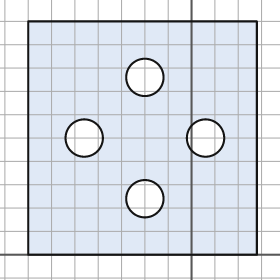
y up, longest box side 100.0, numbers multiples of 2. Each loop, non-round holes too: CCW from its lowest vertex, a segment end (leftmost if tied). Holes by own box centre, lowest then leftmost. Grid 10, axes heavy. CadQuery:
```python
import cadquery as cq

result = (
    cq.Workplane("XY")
    .moveTo(-70.0, 0.0)
    .lineTo(28.0, 0.0)
    .lineTo(28.0, 100.0)
    .lineTo(-70.0, 100.0)
    .close()
    .moveTo(-20.0, 24.0)
    .circle(8.0)
    .moveTo(-46.0, 50.0)
    .circle(8.0)
    .moveTo(6.0, 50.0)
    .circle(8.0)
    .moveTo(-20.0, 76.0)
    .circle(8.0)
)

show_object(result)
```